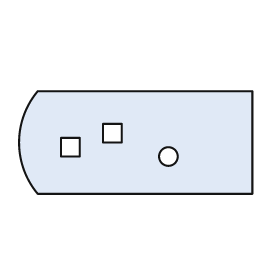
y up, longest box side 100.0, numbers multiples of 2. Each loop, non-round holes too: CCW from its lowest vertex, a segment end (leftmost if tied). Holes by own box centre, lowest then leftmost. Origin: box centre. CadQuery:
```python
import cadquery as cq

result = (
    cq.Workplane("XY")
    .moveTo(-42.0, -22.0)
    .lineTo(50.0, -22.0)
    .lineTo(50.0, 22.0)
    .lineTo(-42.0, 22.0)
    .threePointArc((-50.0, 0.0), (-42.0, -22.0))
    .close()
    .moveTo(14.0, -6.0)
    .circle(4.0)
    .moveTo(-32.0, -6.0)
    .lineTo(-24.0, -6.0)
    .lineTo(-24.0, 2.0)
    .lineTo(-32.0, 2.0)
    .close()
    .moveTo(-14.0, 0.0)
    .lineTo(-6.0, 0.0)
    .lineTo(-6.0, 8.0)
    .lineTo(-14.0, 8.0)
    .close()
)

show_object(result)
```